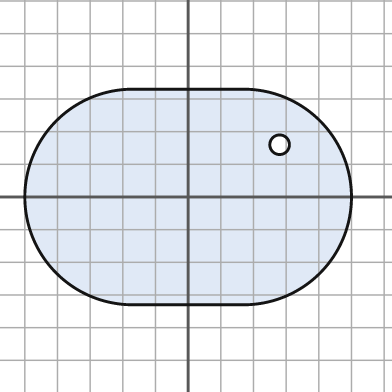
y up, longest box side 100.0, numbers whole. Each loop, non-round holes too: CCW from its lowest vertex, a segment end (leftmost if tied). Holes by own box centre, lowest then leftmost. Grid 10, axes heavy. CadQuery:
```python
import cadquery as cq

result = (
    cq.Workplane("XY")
    .moveTo(-17.0, -33.0)
    .lineTo(17.0, -33.0)
    .threePointArc((50.0, 0.0), (17.0, 33.0))
    .lineTo(-17.0, 33.0)
    .threePointArc((-50.0, 0.0), (-17.0, -33.0))
    .close()
    .moveTo(28.0, 16.0)
    .circle(3.0)
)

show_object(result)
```